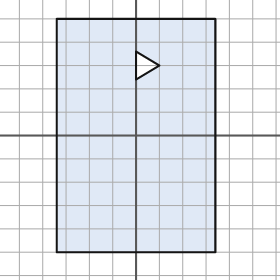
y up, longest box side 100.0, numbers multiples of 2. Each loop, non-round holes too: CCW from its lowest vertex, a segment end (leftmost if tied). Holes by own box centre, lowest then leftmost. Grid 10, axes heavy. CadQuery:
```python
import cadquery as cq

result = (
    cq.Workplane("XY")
    .moveTo(-34.0, -50.0)
    .lineTo(34.0, -50.0)
    .lineTo(34.0, 50.0)
    .lineTo(-34.0, 50.0)
    .close()
    .moveTo(0.0, 24.0)
    .lineTo(10.0, 30.0)
    .lineTo(0.0, 36.0)
    .close()
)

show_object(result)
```